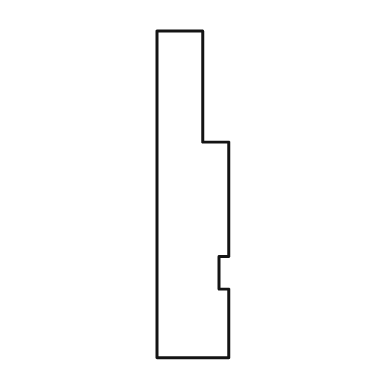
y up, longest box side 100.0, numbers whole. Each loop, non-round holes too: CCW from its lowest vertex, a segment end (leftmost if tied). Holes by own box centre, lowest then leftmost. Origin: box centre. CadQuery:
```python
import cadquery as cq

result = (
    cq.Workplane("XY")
    .moveTo(-11.0, -50.0)
    .lineTo(11.0, -50.0)
    .lineTo(11.0, -29.0)
    .lineTo(8.0, -29.0)
    .lineTo(8.0, -19.0)
    .lineTo(11.0, -19.0)
    .lineTo(11.0, 16.0)
    .lineTo(3.0, 16.0)
    .lineTo(3.0, 50.0)
    .lineTo(-11.0, 50.0)
    .close()
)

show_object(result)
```